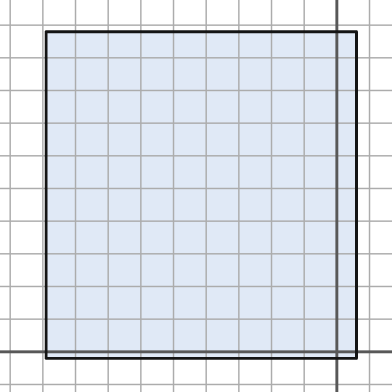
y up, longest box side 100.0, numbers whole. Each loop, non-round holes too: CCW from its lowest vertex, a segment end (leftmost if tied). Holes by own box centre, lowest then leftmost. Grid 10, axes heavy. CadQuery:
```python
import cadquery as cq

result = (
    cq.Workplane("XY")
    .moveTo(-89.0, -2.0)
    .lineTo(6.0, -2.0)
    .lineTo(6.0, 98.0)
    .lineTo(-89.0, 98.0)
    .close()
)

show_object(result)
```